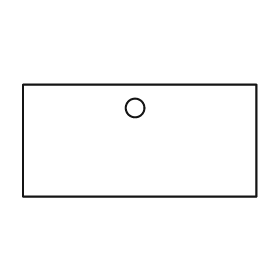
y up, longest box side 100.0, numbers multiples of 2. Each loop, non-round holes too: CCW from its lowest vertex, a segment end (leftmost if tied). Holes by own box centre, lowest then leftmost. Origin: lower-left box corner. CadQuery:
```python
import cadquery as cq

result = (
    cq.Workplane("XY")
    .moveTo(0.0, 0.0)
    .lineTo(100.0, 0.0)
    .lineTo(100.0, 48.0)
    .lineTo(0.0, 48.0)
    .close()
    .moveTo(48.0, 38.0)
    .circle(4.0)
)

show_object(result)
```